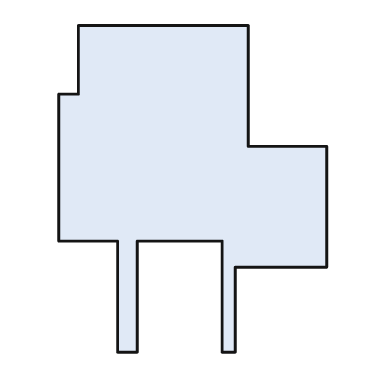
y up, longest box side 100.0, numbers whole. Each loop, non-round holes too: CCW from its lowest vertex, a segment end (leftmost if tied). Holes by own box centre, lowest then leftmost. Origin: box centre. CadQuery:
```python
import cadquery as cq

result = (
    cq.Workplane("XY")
    .moveTo(-23.0, -50.0)
    .lineTo(-17.0, -50.0)
    .lineTo(-17.0, -16.0)
    .lineTo(9.0, -16.0)
    .lineTo(9.0, -50.0)
    .lineTo(13.0, -50.0)
    .lineTo(13.0, -24.0)
    .lineTo(41.0, -24.0)
    .lineTo(41.0, 13.0)
    .lineTo(17.0, 13.0)
    .lineTo(17.0, 50.0)
    .lineTo(-35.0, 50.0)
    .lineTo(-35.0, 29.0)
    .lineTo(-41.0, 29.0)
    .lineTo(-41.0, -16.0)
    .lineTo(-23.0, -16.0)
    .close()
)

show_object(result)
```